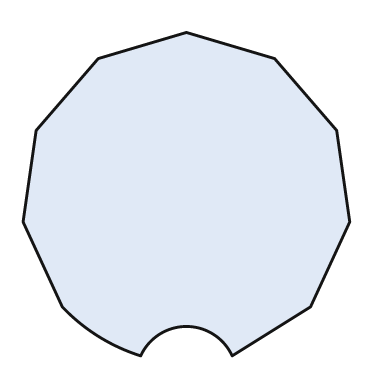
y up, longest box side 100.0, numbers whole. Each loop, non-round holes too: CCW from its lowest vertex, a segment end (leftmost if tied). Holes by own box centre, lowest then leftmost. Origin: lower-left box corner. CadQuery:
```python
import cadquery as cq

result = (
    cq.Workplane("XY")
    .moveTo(36.0, 0.0)
    .threePointArc((50.0, 9.0), (64.0, 0.0))
    .lineTo(88.0, 15.0)
    .lineTo(100.0, 41.0)
    .lineTo(96.0, 69.0)
    .lineTo(77.0, 91.0)
    .lineTo(50.0, 99.0)
    .lineTo(23.0, 91.0)
    .lineTo(4.0, 69.0)
    .lineTo(0.0, 41.0)
    .lineTo(12.0, 15.0)
    .threePointArc((23.0, 6.0), (36.0, 0.0))
    .close()
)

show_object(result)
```